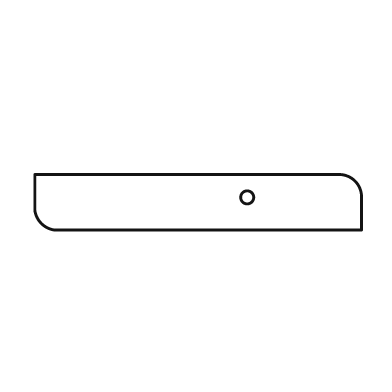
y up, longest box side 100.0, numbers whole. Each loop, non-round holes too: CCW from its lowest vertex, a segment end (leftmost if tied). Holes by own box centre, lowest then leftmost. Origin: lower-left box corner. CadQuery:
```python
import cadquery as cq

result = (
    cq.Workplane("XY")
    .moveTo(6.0, 0.0)
    .lineTo(100.0, 0.0)
    .lineTo(100.0, 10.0)
    .threePointArc((98.0, 15.0), (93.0, 17.0))
    .lineTo(0.0, 17.0)
    .lineTo(0.0, 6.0)
    .threePointArc((2.0, 2.0), (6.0, 0.0))
    .close()
    .moveTo(65.0, 10.0)
    .circle(2.0)
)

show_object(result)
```